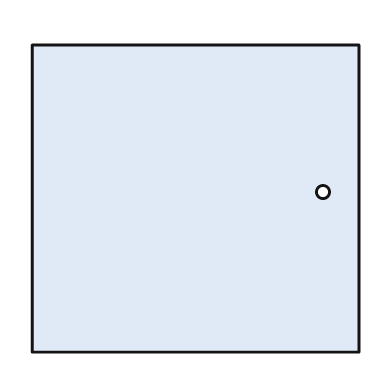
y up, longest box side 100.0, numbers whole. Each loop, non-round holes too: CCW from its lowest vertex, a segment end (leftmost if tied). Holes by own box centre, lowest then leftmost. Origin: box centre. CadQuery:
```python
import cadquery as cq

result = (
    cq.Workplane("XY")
    .moveTo(-50.0, -47.0)
    .lineTo(50.0, -47.0)
    .lineTo(50.0, 47.0)
    .lineTo(-50.0, 47.0)
    .close()
    .moveTo(39.0, 2.0)
    .circle(2.0)
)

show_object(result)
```